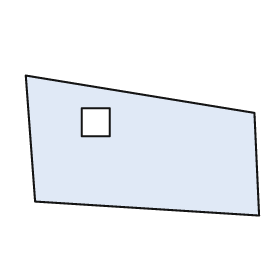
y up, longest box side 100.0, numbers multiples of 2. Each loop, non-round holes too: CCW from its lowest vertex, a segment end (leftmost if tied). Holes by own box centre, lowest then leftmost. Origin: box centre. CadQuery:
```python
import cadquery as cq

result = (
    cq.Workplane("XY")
    .moveTo(50.0, -30.0)
    .lineTo(48.0, 14.0)
    .lineTo(-50.0, 30.0)
    .lineTo(-46.0, -24.0)
    .close()
    .moveTo(-26.0, 4.0)
    .lineTo(-14.0, 4.0)
    .lineTo(-14.0, 16.0)
    .lineTo(-26.0, 16.0)
    .close()
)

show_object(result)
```